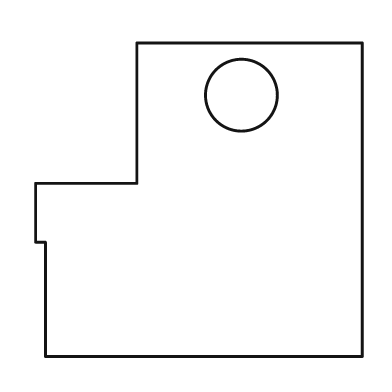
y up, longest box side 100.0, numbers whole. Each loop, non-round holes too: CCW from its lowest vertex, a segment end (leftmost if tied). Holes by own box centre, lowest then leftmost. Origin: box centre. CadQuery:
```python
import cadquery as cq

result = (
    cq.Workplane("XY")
    .moveTo(-47.0, -48.0)
    .lineTo(50.0, -48.0)
    .lineTo(50.0, 48.0)
    .lineTo(-19.0, 48.0)
    .lineTo(-19.0, 5.0)
    .lineTo(-50.0, 5.0)
    .lineTo(-50.0, -13.0)
    .lineTo(-47.0, -13.0)
    .close()
    .moveTo(13.0, 32.0)
    .circle(11.0)
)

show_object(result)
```